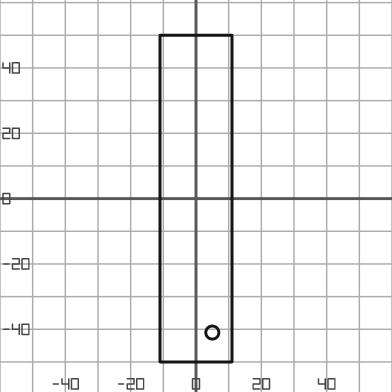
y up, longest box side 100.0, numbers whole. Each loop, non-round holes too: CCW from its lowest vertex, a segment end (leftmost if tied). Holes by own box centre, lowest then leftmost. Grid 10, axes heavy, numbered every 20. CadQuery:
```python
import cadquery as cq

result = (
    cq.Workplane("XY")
    .moveTo(-11.0, -50.0)
    .lineTo(11.0, -50.0)
    .lineTo(11.0, 50.0)
    .lineTo(-11.0, 50.0)
    .close()
    .moveTo(5.0, -41.0)
    .circle(2.0)
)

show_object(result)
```